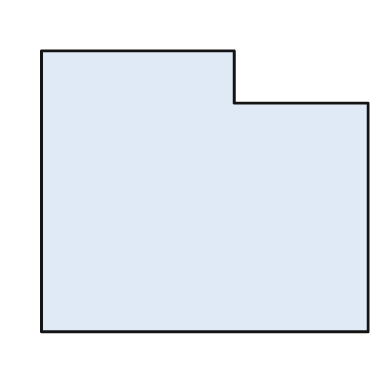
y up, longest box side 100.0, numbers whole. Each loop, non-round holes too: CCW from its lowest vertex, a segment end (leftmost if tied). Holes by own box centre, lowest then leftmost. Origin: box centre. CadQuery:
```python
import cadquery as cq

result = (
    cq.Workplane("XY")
    .moveTo(-50.0, -43.0)
    .lineTo(50.0, -43.0)
    .lineTo(50.0, 27.0)
    .lineTo(9.0, 27.0)
    .lineTo(9.0, 43.0)
    .lineTo(-50.0, 43.0)
    .close()
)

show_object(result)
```